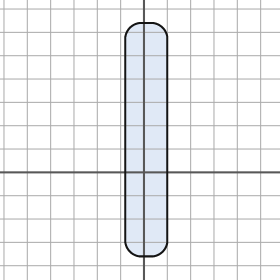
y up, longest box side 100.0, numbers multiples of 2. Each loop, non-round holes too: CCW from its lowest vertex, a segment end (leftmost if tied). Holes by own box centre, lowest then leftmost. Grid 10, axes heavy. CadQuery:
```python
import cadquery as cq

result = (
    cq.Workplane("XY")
    .moveTo(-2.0, -36.0)
    .lineTo(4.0, -36.0)
    .threePointArc((8.0, -34.0), (10.0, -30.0))
    .lineTo(10.0, 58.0)
    .threePointArc((8.0, 62.0), (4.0, 64.0))
    .lineTo(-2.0, 64.0)
    .threePointArc((-6.0, 62.0), (-8.0, 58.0))
    .lineTo(-8.0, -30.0)
    .threePointArc((-6.0, -34.0), (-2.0, -36.0))
    .close()
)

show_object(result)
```